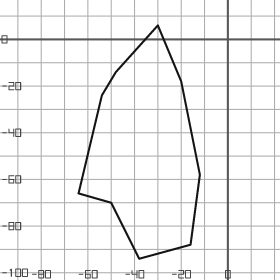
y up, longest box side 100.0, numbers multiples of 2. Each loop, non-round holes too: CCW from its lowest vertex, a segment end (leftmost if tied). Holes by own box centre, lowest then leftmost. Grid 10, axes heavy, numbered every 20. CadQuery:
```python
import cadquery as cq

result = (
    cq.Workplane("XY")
    .moveTo(-38.0, -94.0)
    .lineTo(-16.0, -88.0)
    .lineTo(-12.0, -58.0)
    .lineTo(-20.0, -18.0)
    .lineTo(-30.0, 6.0)
    .lineTo(-48.0, -14.0)
    .lineTo(-54.0, -24.0)
    .lineTo(-64.0, -66.0)
    .lineTo(-50.0, -70.0)
    .close()
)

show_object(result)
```